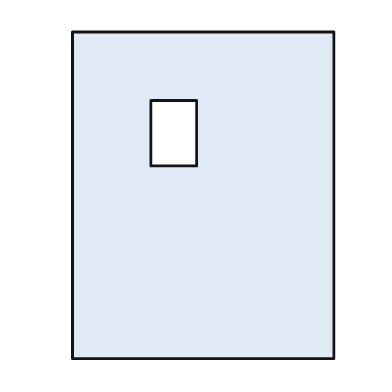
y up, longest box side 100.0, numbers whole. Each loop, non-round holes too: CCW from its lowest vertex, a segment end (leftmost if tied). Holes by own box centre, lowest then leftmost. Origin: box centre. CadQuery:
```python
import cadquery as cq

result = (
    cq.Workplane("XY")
    .moveTo(-40.0, -50.0)
    .lineTo(40.0, -50.0)
    .lineTo(40.0, 50.0)
    .lineTo(-40.0, 50.0)
    .close()
    .moveTo(-16.0, 9.0)
    .lineTo(-2.0, 9.0)
    .lineTo(-2.0, 29.0)
    .lineTo(-16.0, 29.0)
    .close()
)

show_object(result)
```